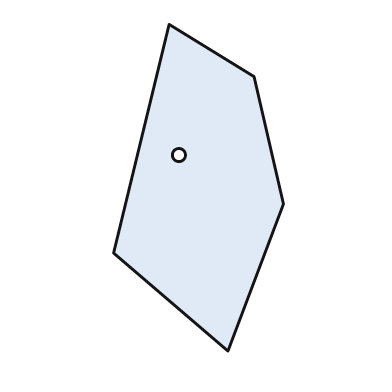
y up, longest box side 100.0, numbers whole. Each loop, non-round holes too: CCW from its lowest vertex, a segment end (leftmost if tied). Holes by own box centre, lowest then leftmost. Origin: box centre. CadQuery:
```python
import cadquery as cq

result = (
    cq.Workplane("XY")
    .moveTo(9.0, -50.0)
    .lineTo(26.0, -5.0)
    .lineTo(17.0, 34.0)
    .lineTo(-9.0, 50.0)
    .lineTo(-26.0, -20.0)
    .close()
    .moveTo(-6.0, 10.0)
    .circle(2.0)
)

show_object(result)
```